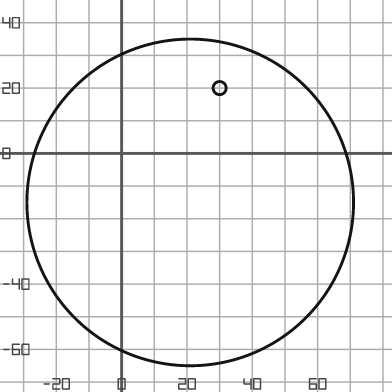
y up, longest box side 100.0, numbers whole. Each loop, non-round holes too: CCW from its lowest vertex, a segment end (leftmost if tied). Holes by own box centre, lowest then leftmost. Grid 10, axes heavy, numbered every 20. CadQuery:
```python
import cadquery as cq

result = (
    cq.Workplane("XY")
    .moveTo(21.0, -15.0)
    .circle(50.0)
    .moveTo(30.0, 20.0)
    .circle(2.0)
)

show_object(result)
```